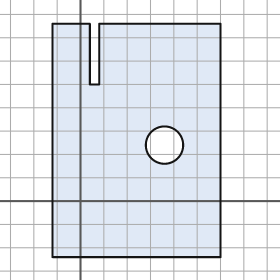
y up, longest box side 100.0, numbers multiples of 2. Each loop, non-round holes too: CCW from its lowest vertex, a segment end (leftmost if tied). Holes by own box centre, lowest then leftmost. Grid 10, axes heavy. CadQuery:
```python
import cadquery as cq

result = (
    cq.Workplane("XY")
    .moveTo(-12.0, -24.0)
    .lineTo(60.0, -24.0)
    .lineTo(60.0, 76.0)
    .lineTo(8.0, 76.0)
    .lineTo(8.0, 50.0)
    .lineTo(4.0, 50.0)
    .lineTo(4.0, 76.0)
    .lineTo(-12.0, 76.0)
    .close()
    .moveTo(36.0, 24.0)
    .circle(8.0)
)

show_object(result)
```